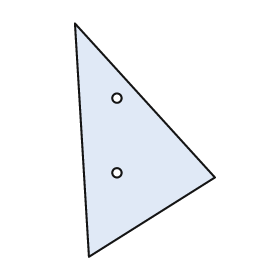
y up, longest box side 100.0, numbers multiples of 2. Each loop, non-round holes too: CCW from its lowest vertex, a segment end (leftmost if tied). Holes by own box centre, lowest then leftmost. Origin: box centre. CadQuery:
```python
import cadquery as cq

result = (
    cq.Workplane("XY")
    .moveTo(-24.0, -50.0)
    .lineTo(30.0, -16.0)
    .lineTo(-30.0, 50.0)
    .close()
    .moveTo(-12.0, -14.0)
    .circle(2.0)
    .moveTo(-12.0, 18.0)
    .circle(2.0)
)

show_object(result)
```